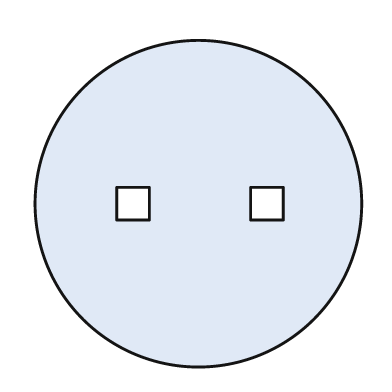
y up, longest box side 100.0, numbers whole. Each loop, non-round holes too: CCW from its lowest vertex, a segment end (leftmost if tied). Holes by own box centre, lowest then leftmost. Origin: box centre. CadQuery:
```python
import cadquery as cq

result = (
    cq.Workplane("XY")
    .moveTo(0.0, 0.0)
    .circle(50.0)
    .moveTo(-25.0, -5.0)
    .lineTo(-15.0, -5.0)
    .lineTo(-15.0, 5.0)
    .lineTo(-25.0, 5.0)
    .close()
    .moveTo(16.0, -5.0)
    .lineTo(26.0, -5.0)
    .lineTo(26.0, 5.0)
    .lineTo(16.0, 5.0)
    .close()
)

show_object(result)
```